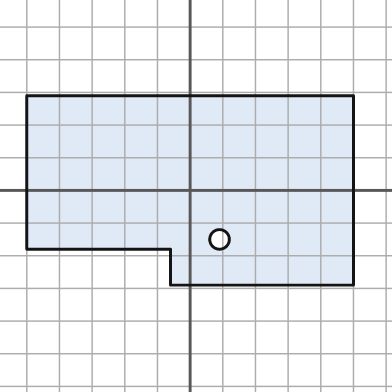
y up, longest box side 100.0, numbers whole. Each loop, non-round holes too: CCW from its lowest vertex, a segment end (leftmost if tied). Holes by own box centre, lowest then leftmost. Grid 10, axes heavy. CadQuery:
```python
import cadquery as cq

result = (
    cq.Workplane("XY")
    .moveTo(-6.0, -29.0)
    .lineTo(50.0, -29.0)
    .lineTo(50.0, 29.0)
    .lineTo(-50.0, 29.0)
    .lineTo(-50.0, -18.0)
    .lineTo(-6.0, -18.0)
    .close()
    .moveTo(9.0, -15.0)
    .circle(3.0)
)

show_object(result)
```